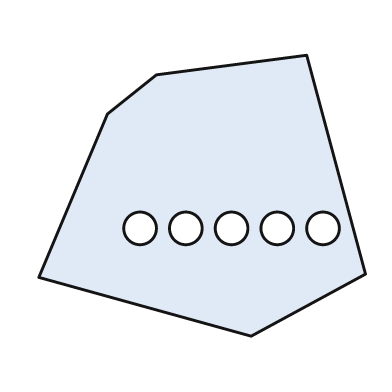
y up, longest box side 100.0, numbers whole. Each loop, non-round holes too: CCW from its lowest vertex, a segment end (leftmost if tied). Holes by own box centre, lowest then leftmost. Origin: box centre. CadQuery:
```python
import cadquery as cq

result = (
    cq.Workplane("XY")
    .moveTo(15.0, -43.0)
    .lineTo(50.0, -24.0)
    .lineTo(32.0, 43.0)
    .lineTo(-14.0, 37.0)
    .lineTo(-29.0, 25.0)
    .lineTo(-50.0, -25.0)
    .close()
    .moveTo(-19.0, -10.0)
    .circle(5.0)
    .moveTo(-5.0, -10.0)
    .circle(5.0)
    .moveTo(9.0, -10.0)
    .circle(5.0)
    .moveTo(23.0, -10.0)
    .circle(5.0)
    .moveTo(37.0, -10.0)
    .circle(5.0)
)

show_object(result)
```